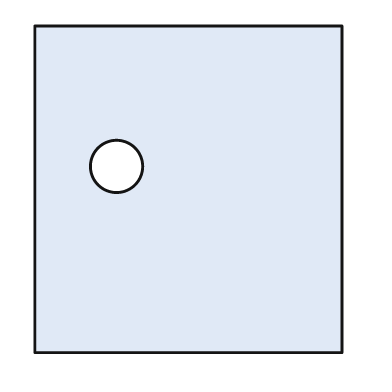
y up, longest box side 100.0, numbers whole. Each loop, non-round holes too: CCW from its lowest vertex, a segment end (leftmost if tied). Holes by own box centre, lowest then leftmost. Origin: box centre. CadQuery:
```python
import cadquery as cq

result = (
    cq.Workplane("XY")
    .moveTo(-47.0, -50.0)
    .lineTo(47.0, -50.0)
    .lineTo(47.0, 50.0)
    .lineTo(-47.0, 50.0)
    .close()
    .moveTo(-22.0, 7.0)
    .circle(8.0)
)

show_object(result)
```